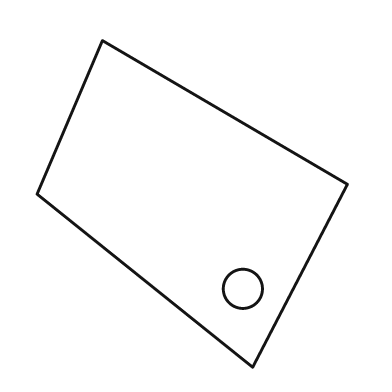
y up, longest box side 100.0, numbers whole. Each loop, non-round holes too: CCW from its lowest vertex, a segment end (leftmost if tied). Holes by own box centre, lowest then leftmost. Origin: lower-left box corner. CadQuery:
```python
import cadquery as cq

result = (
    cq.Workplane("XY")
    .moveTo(66.0, 0.0)
    .lineTo(95.0, 56.0)
    .lineTo(20.0, 100.0)
    .lineTo(0.0, 53.0)
    .close()
    .moveTo(63.0, 24.0)
    .circle(6.0)
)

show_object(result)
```